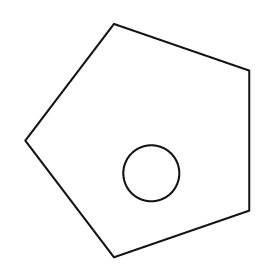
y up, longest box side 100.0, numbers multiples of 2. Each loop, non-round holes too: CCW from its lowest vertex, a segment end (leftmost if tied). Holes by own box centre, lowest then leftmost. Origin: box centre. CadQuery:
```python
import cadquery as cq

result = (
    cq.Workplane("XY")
    .moveTo(-10.0, -50.0)
    .lineTo(48.0, -30.0)
    .lineTo(48.0, 30.0)
    .lineTo(-10.0, 50.0)
    .lineTo(-48.0, 0.0)
    .close()
    .moveTo(6.0, -14.0)
    .circle(12.0)
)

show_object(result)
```